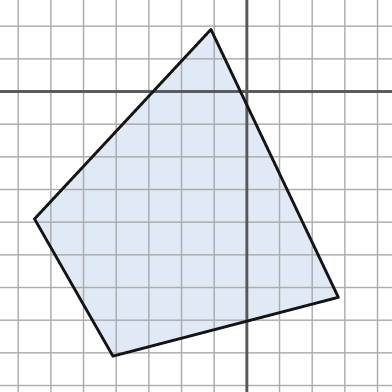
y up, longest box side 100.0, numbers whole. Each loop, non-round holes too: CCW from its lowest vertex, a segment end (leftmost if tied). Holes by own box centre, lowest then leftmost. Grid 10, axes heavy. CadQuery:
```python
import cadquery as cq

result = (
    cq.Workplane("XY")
    .moveTo(-41.0, -81.0)
    .lineTo(28.0, -63.0)
    .lineTo(-11.0, 19.0)
    .lineTo(-65.0, -39.0)
    .close()
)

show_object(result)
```